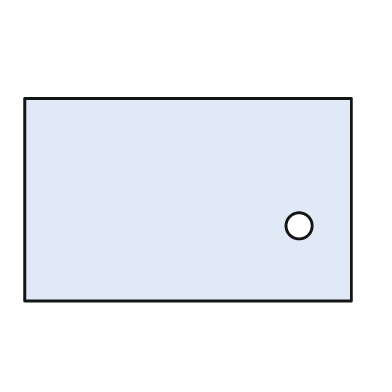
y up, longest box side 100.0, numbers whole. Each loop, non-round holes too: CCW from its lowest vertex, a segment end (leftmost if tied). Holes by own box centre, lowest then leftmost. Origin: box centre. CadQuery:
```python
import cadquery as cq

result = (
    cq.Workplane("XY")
    .moveTo(-50.0, -31.0)
    .lineTo(50.0, -31.0)
    .lineTo(50.0, 31.0)
    .lineTo(-50.0, 31.0)
    .close()
    .moveTo(34.0, -8.0)
    .circle(4.0)
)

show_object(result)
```